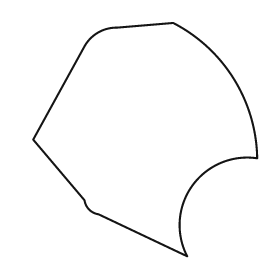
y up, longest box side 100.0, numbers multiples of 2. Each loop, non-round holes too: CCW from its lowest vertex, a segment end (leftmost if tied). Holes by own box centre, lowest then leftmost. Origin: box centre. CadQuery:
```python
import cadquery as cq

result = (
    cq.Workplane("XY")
    .moveTo(18.0, -50.0)
    .threePointArc((20.0, -20.0), (48.0, -8.0))
    .threePointArc((38.0, 26.0), (12.0, 50.0))
    .lineTo(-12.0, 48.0)
    .threePointArc((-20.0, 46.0), (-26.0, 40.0))
    .lineTo(-48.0, 0.0)
    .lineTo(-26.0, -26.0)
    .threePointArc((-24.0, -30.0), (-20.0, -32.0))
    .close()
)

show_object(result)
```